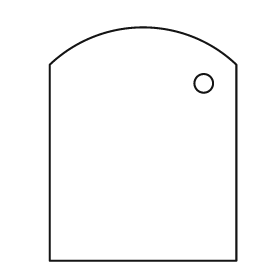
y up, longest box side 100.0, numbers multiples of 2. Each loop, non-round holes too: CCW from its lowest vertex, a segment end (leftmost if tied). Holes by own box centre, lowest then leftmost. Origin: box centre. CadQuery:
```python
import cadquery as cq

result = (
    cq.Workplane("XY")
    .moveTo(-40.0, -50.0)
    .lineTo(40.0, -50.0)
    .lineTo(40.0, 34.0)
    .threePointArc((0.0, 50.0), (-40.0, 34.0))
    .close()
    .moveTo(26.0, 26.0)
    .circle(4.0)
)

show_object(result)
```